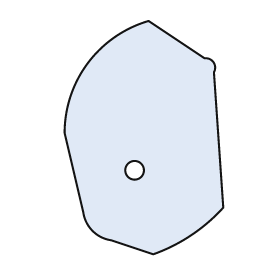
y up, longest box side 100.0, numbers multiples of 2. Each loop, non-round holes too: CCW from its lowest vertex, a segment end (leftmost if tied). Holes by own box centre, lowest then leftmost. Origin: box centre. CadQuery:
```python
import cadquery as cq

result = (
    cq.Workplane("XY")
    .moveTo(4.0, -50.0)
    .threePointArc((20.0, -42.0), (34.0, -30.0))
    .lineTo(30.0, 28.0)
    .threePointArc((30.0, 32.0), (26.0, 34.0))
    .lineTo(2.0, 50.0)
    .threePointArc((-24.0, 32.0), (-34.0, 2.0))
    .lineTo(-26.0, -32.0)
    .threePointArc((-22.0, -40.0), (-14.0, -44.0))
    .close()
    .moveTo(-4.0, -14.0)
    .circle(4.0)
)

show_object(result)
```